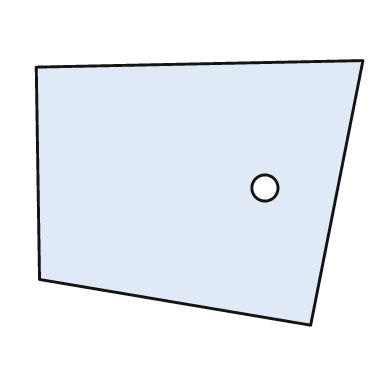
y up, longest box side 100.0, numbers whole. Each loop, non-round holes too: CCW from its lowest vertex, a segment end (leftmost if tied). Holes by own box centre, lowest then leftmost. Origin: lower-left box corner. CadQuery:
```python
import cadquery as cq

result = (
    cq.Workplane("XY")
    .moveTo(84.0, 0.0)
    .lineTo(100.0, 81.0)
    .lineTo(0.0, 79.0)
    .lineTo(1.0, 14.0)
    .close()
    .moveTo(70.0, 42.0)
    .circle(4.0)
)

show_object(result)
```